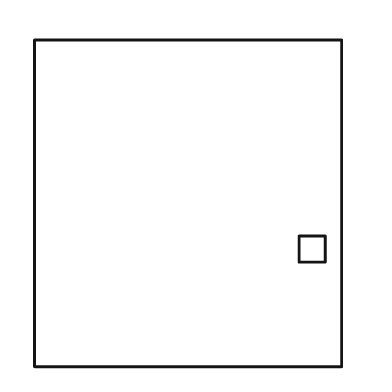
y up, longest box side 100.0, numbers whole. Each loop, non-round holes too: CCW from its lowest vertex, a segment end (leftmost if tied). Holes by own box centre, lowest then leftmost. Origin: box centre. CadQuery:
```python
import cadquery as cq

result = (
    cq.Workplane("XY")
    .moveTo(-47.0, -50.0)
    .lineTo(47.0, -50.0)
    .lineTo(47.0, 50.0)
    .lineTo(-47.0, 50.0)
    .close()
    .moveTo(34.0, -18.0)
    .lineTo(42.0, -18.0)
    .lineTo(42.0, -10.0)
    .lineTo(34.0, -10.0)
    .close()
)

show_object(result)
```